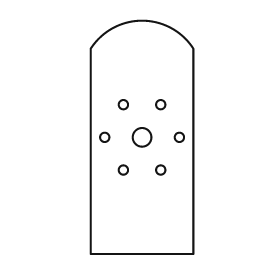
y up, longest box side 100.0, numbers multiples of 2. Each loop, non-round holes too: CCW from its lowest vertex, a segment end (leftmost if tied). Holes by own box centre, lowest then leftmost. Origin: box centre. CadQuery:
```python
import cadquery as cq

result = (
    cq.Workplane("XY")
    .moveTo(-22.0, -50.0)
    .lineTo(22.0, -50.0)
    .lineTo(22.0, 38.0)
    .threePointArc((0.0, 50.0), (-22.0, 38.0))
    .close()
    .moveTo(-8.0, -14.0)
    .circle(2.0)
    .moveTo(8.0, -14.0)
    .circle(2.0)
    .moveTo(-16.0, 0.0)
    .circle(2.0)
    .moveTo(0.0, 0.0)
    .circle(4.0)
    .moveTo(16.0, 0.0)
    .circle(2.0)
    .moveTo(-8.0, 14.0)
    .circle(2.0)
    .moveTo(8.0, 14.0)
    .circle(2.0)
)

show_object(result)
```